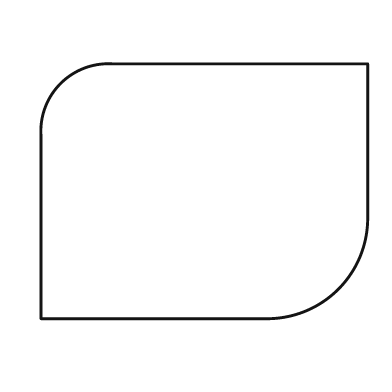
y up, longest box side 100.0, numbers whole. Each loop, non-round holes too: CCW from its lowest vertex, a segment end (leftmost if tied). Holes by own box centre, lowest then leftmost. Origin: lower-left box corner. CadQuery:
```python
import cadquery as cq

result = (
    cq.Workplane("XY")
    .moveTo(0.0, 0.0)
    .lineTo(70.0, 0.0)
    .threePointArc((91.0, 9.0), (100.0, 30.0))
    .lineTo(100.0, 78.0)
    .lineTo(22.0, 78.0)
    .threePointArc((6.0, 72.0), (0.0, 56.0))
    .close()
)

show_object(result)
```